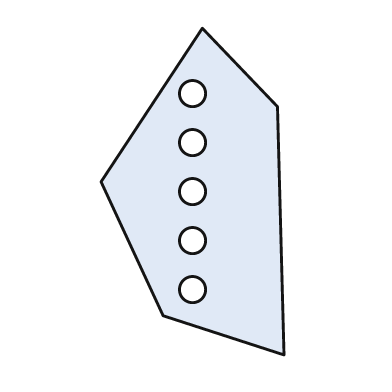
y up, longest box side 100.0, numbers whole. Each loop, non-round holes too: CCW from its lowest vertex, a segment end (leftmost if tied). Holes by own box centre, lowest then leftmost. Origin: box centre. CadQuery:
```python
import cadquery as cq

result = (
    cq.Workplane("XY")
    .moveTo(28.0, -50.0)
    .lineTo(26.0, 26.0)
    .lineTo(3.0, 50.0)
    .lineTo(-28.0, 3.0)
    .lineTo(-9.0, -38.0)
    .close()
    .moveTo(0.0, -30.0)
    .circle(4.0)
    .moveTo(0.0, -15.0)
    .circle(4.0)
    .moveTo(0.0, 0.0)
    .circle(4.0)
    .moveTo(0.0, 15.0)
    .circle(4.0)
    .moveTo(0.0, 30.0)
    .circle(4.0)
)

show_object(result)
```